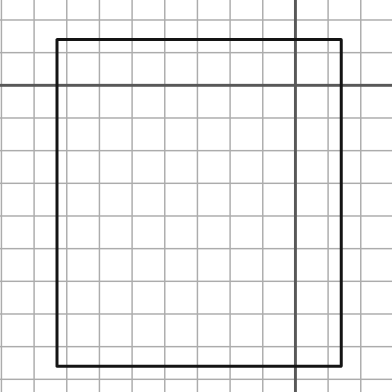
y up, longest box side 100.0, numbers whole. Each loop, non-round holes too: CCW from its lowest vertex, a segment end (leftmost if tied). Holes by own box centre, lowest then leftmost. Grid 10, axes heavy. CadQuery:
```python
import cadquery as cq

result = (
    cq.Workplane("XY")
    .moveTo(-73.0, -86.0)
    .lineTo(14.0, -86.0)
    .lineTo(14.0, 14.0)
    .lineTo(-73.0, 14.0)
    .close()
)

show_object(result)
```